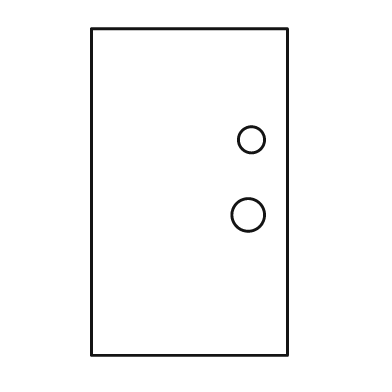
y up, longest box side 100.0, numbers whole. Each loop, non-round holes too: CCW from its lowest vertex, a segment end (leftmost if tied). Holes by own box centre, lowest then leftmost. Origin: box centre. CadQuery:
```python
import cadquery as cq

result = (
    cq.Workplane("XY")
    .moveTo(-30.0, -50.0)
    .lineTo(30.0, -50.0)
    .lineTo(30.0, 50.0)
    .lineTo(-30.0, 50.0)
    .close()
    .moveTo(18.0, -7.0)
    .circle(5.0)
    .moveTo(19.0, 16.0)
    .circle(4.0)
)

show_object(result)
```